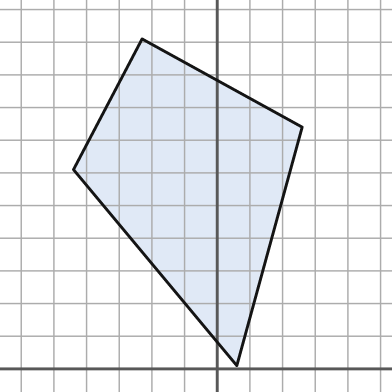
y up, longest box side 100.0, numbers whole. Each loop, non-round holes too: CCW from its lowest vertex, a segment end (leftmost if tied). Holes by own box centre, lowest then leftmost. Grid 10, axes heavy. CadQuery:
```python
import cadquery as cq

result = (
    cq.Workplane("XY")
    .moveTo(6.0, 1.0)
    .lineTo(26.0, 74.0)
    .lineTo(-23.0, 101.0)
    .lineTo(-44.0, 61.0)
    .close()
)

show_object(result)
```